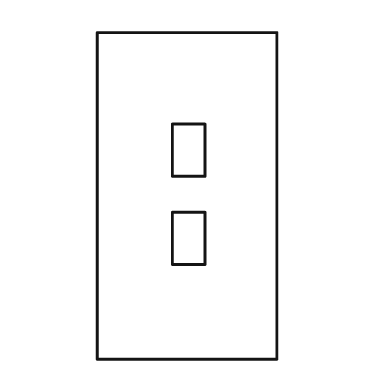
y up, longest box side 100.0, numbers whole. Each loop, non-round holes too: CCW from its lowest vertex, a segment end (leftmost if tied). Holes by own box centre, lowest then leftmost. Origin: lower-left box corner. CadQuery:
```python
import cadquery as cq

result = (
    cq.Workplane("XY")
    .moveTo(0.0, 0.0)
    .lineTo(55.0, 0.0)
    .lineTo(55.0, 100.0)
    .lineTo(0.0, 100.0)
    .close()
    .moveTo(23.0, 29.0)
    .lineTo(33.0, 29.0)
    .lineTo(33.0, 45.0)
    .lineTo(23.0, 45.0)
    .close()
    .moveTo(23.0, 56.0)
    .lineTo(33.0, 56.0)
    .lineTo(33.0, 72.0)
    .lineTo(23.0, 72.0)
    .close()
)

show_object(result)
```